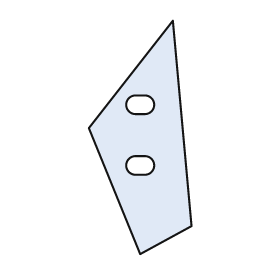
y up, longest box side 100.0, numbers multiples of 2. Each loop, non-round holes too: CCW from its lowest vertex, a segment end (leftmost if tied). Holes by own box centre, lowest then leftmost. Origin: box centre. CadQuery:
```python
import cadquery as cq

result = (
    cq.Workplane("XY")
    .moveTo(0.0, -50.0)
    .lineTo(22.0, -38.0)
    .lineTo(14.0, 50.0)
    .lineTo(-22.0, 4.0)
    .close()
    .moveTo(-2.0, -16.0)
    .lineTo(2.0, -16.0)
    .threePointArc((6.0, -12.0), (2.0, -8.0))
    .lineTo(-2.0, -8.0)
    .threePointArc((-6.0, -12.0), (-2.0, -16.0))
    .close()
    .moveTo(-2.0, 10.0)
    .lineTo(2.0, 10.0)
    .threePointArc((6.0, 14.0), (2.0, 18.0))
    .lineTo(-2.0, 18.0)
    .threePointArc((-6.0, 14.0), (-2.0, 10.0))
    .close()
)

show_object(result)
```